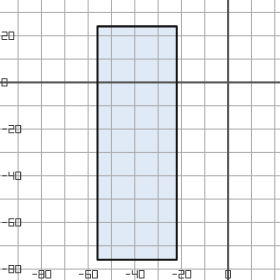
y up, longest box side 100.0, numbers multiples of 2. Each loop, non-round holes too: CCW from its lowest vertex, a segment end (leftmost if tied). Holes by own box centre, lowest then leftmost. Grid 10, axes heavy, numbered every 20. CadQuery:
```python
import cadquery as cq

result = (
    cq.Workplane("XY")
    .moveTo(-56.0, -76.0)
    .lineTo(-22.0, -76.0)
    .lineTo(-22.0, 24.0)
    .lineTo(-56.0, 24.0)
    .close()
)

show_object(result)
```